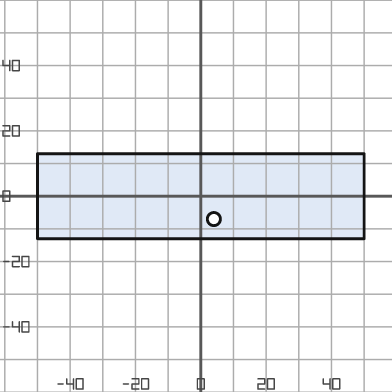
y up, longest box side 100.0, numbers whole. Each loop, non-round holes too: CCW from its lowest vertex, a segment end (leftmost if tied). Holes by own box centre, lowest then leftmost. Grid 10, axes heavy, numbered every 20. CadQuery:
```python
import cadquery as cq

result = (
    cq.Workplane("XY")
    .moveTo(-50.0, -13.0)
    .lineTo(50.0, -13.0)
    .lineTo(50.0, 13.0)
    .lineTo(-50.0, 13.0)
    .close()
    .moveTo(4.0, -7.0)
    .circle(2.0)
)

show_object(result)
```